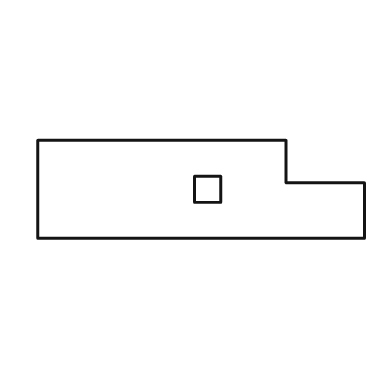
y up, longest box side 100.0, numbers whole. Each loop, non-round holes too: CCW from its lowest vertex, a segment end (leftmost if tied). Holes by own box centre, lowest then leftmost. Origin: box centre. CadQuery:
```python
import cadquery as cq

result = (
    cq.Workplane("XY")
    .moveTo(-50.0, -15.0)
    .lineTo(50.0, -15.0)
    .lineTo(50.0, 2.0)
    .lineTo(26.0, 2.0)
    .lineTo(26.0, 15.0)
    .lineTo(-50.0, 15.0)
    .close()
    .moveTo(-2.0, -4.0)
    .lineTo(6.0, -4.0)
    .lineTo(6.0, 4.0)
    .lineTo(-2.0, 4.0)
    .close()
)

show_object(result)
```